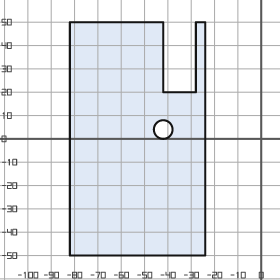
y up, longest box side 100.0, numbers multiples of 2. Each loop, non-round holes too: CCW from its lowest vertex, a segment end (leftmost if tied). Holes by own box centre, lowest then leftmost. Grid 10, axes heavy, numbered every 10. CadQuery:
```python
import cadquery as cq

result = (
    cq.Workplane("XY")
    .moveTo(-82.0, -50.0)
    .lineTo(-24.0, -50.0)
    .lineTo(-24.0, 50.0)
    .lineTo(-28.0, 50.0)
    .lineTo(-28.0, 20.0)
    .lineTo(-42.0, 20.0)
    .lineTo(-42.0, 50.0)
    .lineTo(-82.0, 50.0)
    .close()
    .moveTo(-42.0, 4.0)
    .circle(4.0)
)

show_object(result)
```